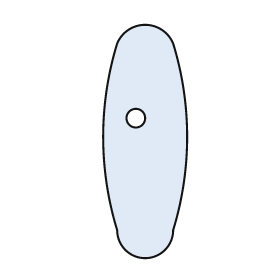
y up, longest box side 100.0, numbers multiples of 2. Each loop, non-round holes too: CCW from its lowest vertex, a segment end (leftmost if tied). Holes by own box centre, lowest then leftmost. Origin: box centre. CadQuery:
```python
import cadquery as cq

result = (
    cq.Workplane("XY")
    .moveTo(-12.0, -38.0)
    .threePointArc((0.0, -50.0), (12.0, -38.0))
    .threePointArc((18.0, 2.0), (12.0, 42.0))
    .threePointArc((0.0, 50.0), (-12.0, 42.0))
    .threePointArc((-18.0, 2.0), (-12.0, -38.0))
    .close()
    .moveTo(-4.0, 10.0)
    .circle(4.0)
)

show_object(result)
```